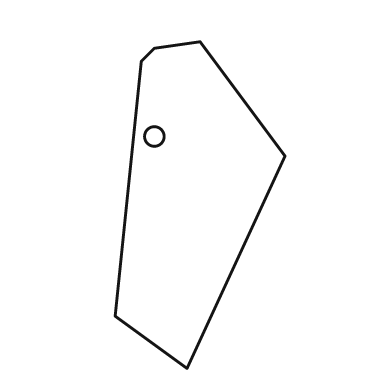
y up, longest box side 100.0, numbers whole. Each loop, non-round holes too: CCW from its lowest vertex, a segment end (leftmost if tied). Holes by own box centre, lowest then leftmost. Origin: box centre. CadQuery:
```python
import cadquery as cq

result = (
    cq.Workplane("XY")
    .moveTo(-4.0, -50.0)
    .lineTo(26.0, 15.0)
    .lineTo(0.0, 50.0)
    .lineTo(-14.0, 48.0)
    .lineTo(-18.0, 44.0)
    .lineTo(-26.0, -34.0)
    .close()
    .moveTo(-14.0, 21.0)
    .circle(3.0)
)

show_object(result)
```